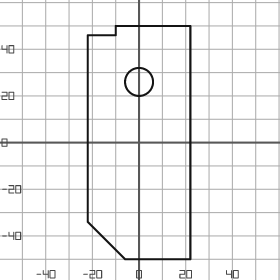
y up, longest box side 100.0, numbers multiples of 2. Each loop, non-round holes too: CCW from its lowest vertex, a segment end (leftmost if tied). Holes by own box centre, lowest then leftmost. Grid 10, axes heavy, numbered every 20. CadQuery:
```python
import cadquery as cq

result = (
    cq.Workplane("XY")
    .moveTo(-6.0, -50.0)
    .lineTo(22.0, -50.0)
    .lineTo(22.0, 50.0)
    .lineTo(-10.0, 50.0)
    .lineTo(-10.0, 46.0)
    .lineTo(-22.0, 46.0)
    .lineTo(-22.0, -34.0)
    .close()
    .moveTo(0.0, 26.0)
    .circle(6.0)
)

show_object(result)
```